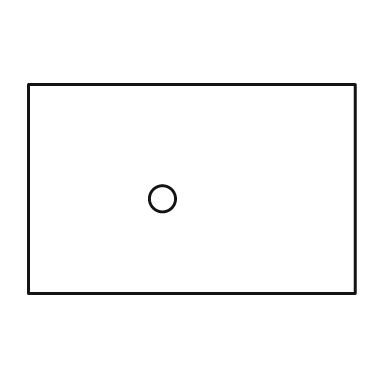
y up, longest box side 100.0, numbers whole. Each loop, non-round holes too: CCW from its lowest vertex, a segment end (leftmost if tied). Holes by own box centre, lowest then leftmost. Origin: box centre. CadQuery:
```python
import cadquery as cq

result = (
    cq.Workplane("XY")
    .moveTo(-50.0, -32.0)
    .lineTo(50.0, -32.0)
    .lineTo(50.0, 32.0)
    .lineTo(-50.0, 32.0)
    .close()
    .moveTo(-9.0, -3.0)
    .circle(4.0)
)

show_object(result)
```